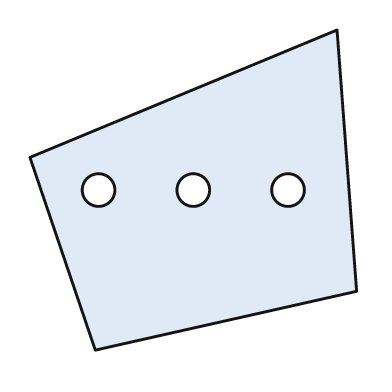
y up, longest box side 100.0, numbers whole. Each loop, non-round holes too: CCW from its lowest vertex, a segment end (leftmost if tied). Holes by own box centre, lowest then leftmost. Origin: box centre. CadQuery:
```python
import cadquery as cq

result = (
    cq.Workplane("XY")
    .moveTo(-30.0, -49.0)
    .lineTo(50.0, -31.0)
    .lineTo(44.0, 49.0)
    .lineTo(-50.0, 10.0)
    .close()
    .moveTo(-29.0, 0.0)
    .circle(5.0)
    .moveTo(0.0, 0.0)
    .circle(5.0)
    .moveTo(29.0, 0.0)
    .circle(5.0)
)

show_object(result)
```